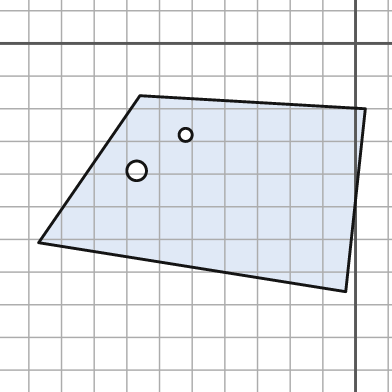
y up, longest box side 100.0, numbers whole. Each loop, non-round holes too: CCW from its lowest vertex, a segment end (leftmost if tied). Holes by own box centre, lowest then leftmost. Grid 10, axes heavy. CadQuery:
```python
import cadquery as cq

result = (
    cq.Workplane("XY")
    .moveTo(-3.0, -76.0)
    .lineTo(3.0, -20.0)
    .lineTo(-66.0, -16.0)
    .lineTo(-97.0, -61.0)
    .close()
    .moveTo(-67.0, -39.0)
    .circle(3.0)
    .moveTo(-52.0, -28.0)
    .circle(2.0)
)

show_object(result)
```